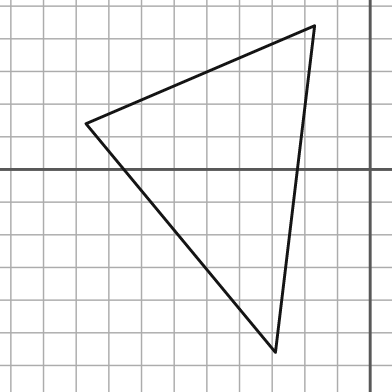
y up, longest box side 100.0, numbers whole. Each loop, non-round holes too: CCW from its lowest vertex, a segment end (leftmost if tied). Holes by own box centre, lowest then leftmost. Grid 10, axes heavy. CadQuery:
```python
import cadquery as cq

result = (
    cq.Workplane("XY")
    .moveTo(-29.0, -56.0)
    .lineTo(-17.0, 44.0)
    .lineTo(-87.0, 14.0)
    .close()
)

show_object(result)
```